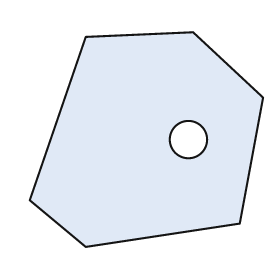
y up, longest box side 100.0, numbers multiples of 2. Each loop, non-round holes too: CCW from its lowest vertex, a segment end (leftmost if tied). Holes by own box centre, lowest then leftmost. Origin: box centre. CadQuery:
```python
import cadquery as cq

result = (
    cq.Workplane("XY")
    .moveTo(-26.0, -46.0)
    .lineTo(40.0, -36.0)
    .lineTo(50.0, 18.0)
    .lineTo(20.0, 46.0)
    .lineTo(-26.0, 44.0)
    .lineTo(-50.0, -26.0)
    .close()
    .moveTo(18.0, 0.0)
    .circle(8.0)
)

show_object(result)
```